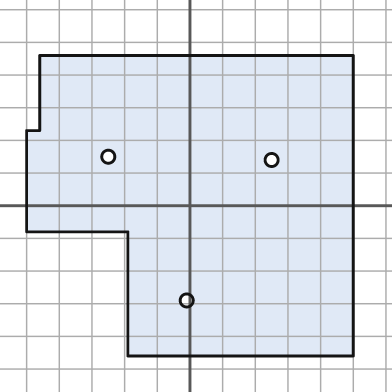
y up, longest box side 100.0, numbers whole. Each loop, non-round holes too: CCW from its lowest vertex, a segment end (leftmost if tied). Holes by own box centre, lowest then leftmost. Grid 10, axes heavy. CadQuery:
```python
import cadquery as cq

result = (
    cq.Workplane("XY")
    .moveTo(-19.0, -46.0)
    .lineTo(50.0, -46.0)
    .lineTo(50.0, 46.0)
    .lineTo(-46.0, 46.0)
    .lineTo(-46.0, 23.0)
    .lineTo(-50.0, 23.0)
    .lineTo(-50.0, -8.0)
    .lineTo(-19.0, -8.0)
    .close()
    .moveTo(-1.0, -29.0)
    .circle(2.0)
    .moveTo(25.0, 14.0)
    .circle(2.0)
    .moveTo(-25.0, 15.0)
    .circle(2.0)
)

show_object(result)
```